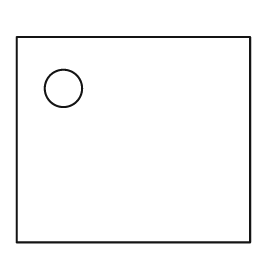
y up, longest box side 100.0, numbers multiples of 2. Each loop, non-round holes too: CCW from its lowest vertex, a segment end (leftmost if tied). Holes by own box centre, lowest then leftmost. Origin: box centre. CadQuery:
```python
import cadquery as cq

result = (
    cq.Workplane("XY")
    .moveTo(-50.0, -44.0)
    .lineTo(50.0, -44.0)
    .lineTo(50.0, 44.0)
    .lineTo(-50.0, 44.0)
    .close()
    .moveTo(-30.0, 22.0)
    .circle(8.0)
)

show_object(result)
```